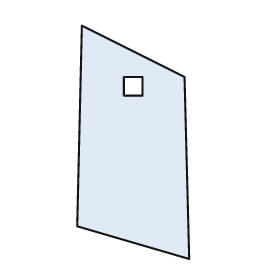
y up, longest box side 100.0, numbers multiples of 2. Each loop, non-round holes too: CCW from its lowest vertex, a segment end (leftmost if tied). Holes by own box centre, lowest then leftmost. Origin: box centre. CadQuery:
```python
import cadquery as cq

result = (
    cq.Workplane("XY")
    .moveTo(24.0, -50.0)
    .lineTo(22.0, 28.0)
    .lineTo(-22.0, 50.0)
    .lineTo(-24.0, -36.0)
    .close()
    .moveTo(-4.0, 20.0)
    .lineTo(4.0, 20.0)
    .lineTo(4.0, 28.0)
    .lineTo(-4.0, 28.0)
    .close()
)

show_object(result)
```